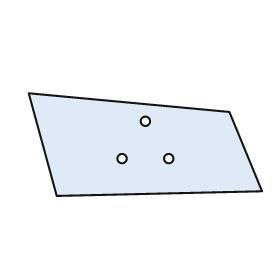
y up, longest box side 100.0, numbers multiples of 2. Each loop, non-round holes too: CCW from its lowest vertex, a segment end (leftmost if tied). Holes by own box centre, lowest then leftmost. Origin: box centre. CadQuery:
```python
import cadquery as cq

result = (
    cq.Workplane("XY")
    .moveTo(-38.0, -22.0)
    .lineTo(50.0, -20.0)
    .lineTo(36.0, 14.0)
    .lineTo(-50.0, 22.0)
    .close()
    .moveTo(-10.0, -6.0)
    .circle(2.0)
    .moveTo(10.0, -6.0)
    .circle(2.0)
    .moveTo(0.0, 10.0)
    .circle(2.0)
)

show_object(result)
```